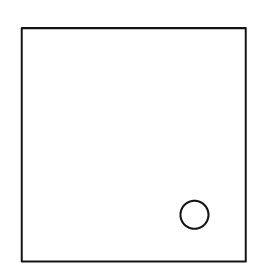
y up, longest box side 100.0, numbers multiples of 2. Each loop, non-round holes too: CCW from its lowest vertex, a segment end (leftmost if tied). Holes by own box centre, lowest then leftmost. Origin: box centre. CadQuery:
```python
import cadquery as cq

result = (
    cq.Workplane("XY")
    .moveTo(-48.0, -50.0)
    .lineTo(48.0, -50.0)
    .lineTo(48.0, 50.0)
    .lineTo(-48.0, 50.0)
    .close()
    .moveTo(26.0, -30.0)
    .circle(6.0)
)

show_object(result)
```